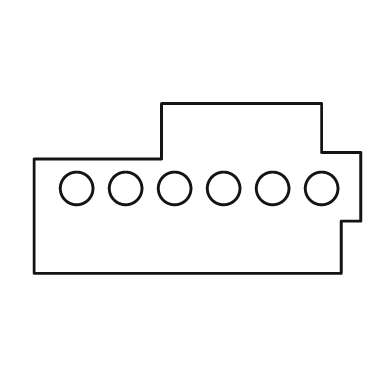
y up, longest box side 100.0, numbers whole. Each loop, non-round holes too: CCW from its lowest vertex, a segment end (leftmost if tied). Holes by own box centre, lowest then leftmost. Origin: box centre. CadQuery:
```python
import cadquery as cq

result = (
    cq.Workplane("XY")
    .moveTo(-50.0, -26.0)
    .lineTo(44.0, -26.0)
    .lineTo(44.0, -10.0)
    .lineTo(50.0, -10.0)
    .lineTo(50.0, 11.0)
    .lineTo(38.0, 11.0)
    .lineTo(38.0, 26.0)
    .lineTo(-11.0, 26.0)
    .lineTo(-11.0, 9.0)
    .lineTo(-50.0, 9.0)
    .close()
    .moveTo(-37.0, 0.0)
    .circle(5.0)
    .moveTo(-22.0, 0.0)
    .circle(5.0)
    .moveTo(-7.0, 0.0)
    .circle(5.0)
    .moveTo(8.0, 0.0)
    .circle(5.0)
    .moveTo(23.0, 0.0)
    .circle(5.0)
    .moveTo(38.0, 0.0)
    .circle(5.0)
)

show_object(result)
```